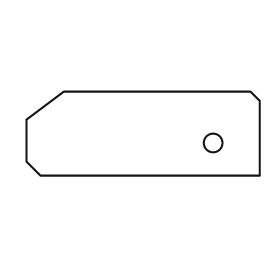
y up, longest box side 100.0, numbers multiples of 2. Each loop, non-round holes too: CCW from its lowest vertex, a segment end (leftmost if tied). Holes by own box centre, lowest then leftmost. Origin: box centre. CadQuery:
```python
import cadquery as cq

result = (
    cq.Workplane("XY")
    .moveTo(-44.0, -18.0)
    .lineTo(50.0, -18.0)
    .lineTo(50.0, 14.0)
    .lineTo(46.0, 18.0)
    .lineTo(-34.0, 18.0)
    .lineTo(-50.0, 6.0)
    .lineTo(-50.0, -12.0)
    .close()
    .moveTo(30.0, -4.0)
    .circle(4.0)
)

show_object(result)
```